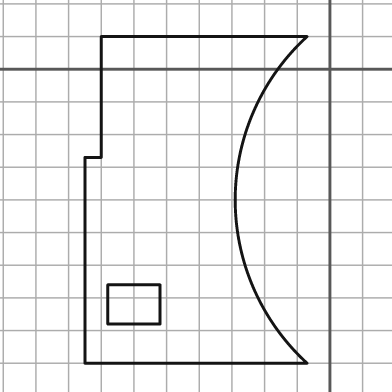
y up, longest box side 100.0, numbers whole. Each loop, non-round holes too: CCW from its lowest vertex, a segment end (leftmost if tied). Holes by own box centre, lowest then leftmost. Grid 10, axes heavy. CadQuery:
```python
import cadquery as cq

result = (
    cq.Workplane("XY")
    .moveTo(-75.0, -90.0)
    .lineTo(-7.0, -90.0)
    .threePointArc((-29.0, -40.0), (-7.0, 10.0))
    .lineTo(-70.0, 10.0)
    .lineTo(-70.0, -27.0)
    .lineTo(-75.0, -27.0)
    .close()
    .moveTo(-68.0, -78.0)
    .lineTo(-52.0, -78.0)
    .lineTo(-52.0, -66.0)
    .lineTo(-68.0, -66.0)
    .close()
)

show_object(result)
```